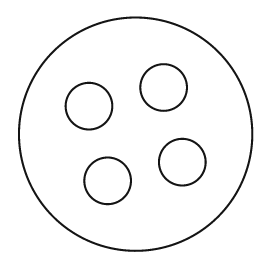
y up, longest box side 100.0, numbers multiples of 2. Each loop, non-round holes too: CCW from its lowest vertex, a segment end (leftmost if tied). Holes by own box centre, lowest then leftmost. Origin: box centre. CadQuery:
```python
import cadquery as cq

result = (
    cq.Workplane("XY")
    .moveTo(0.0, 0.0)
    .circle(50.0)
    .moveTo(-12.0, -20.0)
    .circle(10.0)
    .moveTo(20.0, -12.0)
    .circle(10.0)
    .moveTo(-20.0, 12.0)
    .circle(10.0)
    .moveTo(12.0, 20.0)
    .circle(10.0)
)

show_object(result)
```